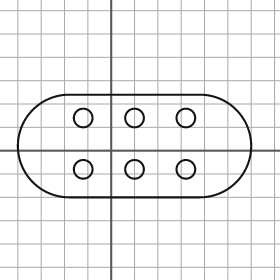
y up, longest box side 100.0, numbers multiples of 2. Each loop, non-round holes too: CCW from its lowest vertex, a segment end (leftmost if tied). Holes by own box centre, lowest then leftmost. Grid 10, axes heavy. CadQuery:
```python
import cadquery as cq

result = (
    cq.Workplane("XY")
    .moveTo(-18.0, -20.0)
    .lineTo(38.0, -20.0)
    .threePointArc((60.0, 2.0), (38.0, 24.0))
    .lineTo(-18.0, 24.0)
    .threePointArc((-40.0, 2.0), (-18.0, -20.0))
    .close()
    .moveTo(-12.0, -8.0)
    .circle(4.0)
    .moveTo(10.0, -8.0)
    .circle(4.0)
    .moveTo(32.0, -8.0)
    .circle(4.0)
    .moveTo(-12.0, 14.0)
    .circle(4.0)
    .moveTo(10.0, 14.0)
    .circle(4.0)
    .moveTo(32.0, 14.0)
    .circle(4.0)
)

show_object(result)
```